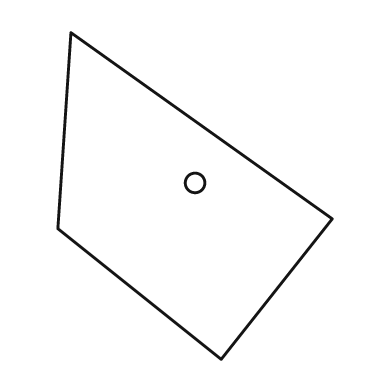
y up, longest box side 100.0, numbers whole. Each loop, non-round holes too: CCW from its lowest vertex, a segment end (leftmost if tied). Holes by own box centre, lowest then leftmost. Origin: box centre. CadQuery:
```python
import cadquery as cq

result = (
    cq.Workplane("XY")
    .moveTo(8.0, -50.0)
    .lineTo(42.0, -7.0)
    .lineTo(-38.0, 50.0)
    .lineTo(-42.0, -10.0)
    .close()
    .moveTo(0.0, 4.0)
    .circle(3.0)
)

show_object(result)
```